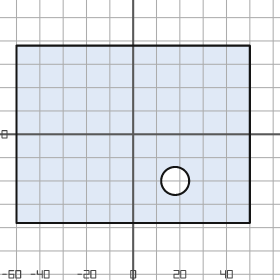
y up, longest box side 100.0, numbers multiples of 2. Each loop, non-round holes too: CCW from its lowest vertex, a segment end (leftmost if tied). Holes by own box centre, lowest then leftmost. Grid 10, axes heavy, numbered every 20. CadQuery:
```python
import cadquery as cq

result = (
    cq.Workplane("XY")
    .moveTo(-50.0, -38.0)
    .lineTo(50.0, -38.0)
    .lineTo(50.0, 38.0)
    .lineTo(-50.0, 38.0)
    .close()
    .moveTo(18.0, -20.0)
    .circle(6.0)
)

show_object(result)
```